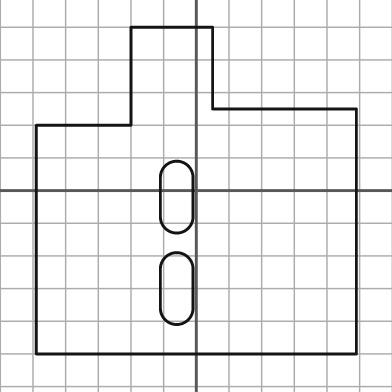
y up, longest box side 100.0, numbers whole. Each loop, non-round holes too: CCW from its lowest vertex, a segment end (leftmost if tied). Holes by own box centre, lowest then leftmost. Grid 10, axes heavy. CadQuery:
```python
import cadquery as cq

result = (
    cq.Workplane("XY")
    .moveTo(-49.0, -50.0)
    .lineTo(49.0, -50.0)
    .lineTo(49.0, 25.0)
    .lineTo(5.0, 25.0)
    .lineTo(5.0, 50.0)
    .lineTo(-20.0, 50.0)
    .lineTo(-20.0, 20.0)
    .lineTo(-49.0, 20.0)
    .close()
    .moveTo(-11.0, -36.0)
    .threePointArc((-6.0, -41.0), (-1.0, -36.0))
    .lineTo(-1.0, -24.0)
    .threePointArc((-6.0, -19.0), (-11.0, -24.0))
    .close()
    .moveTo(-11.0, -8.0)
    .threePointArc((-6.0, -13.0), (-1.0, -8.0))
    .lineTo(-1.0, 4.0)
    .threePointArc((-6.0, 9.0), (-11.0, 4.0))
    .close()
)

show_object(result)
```